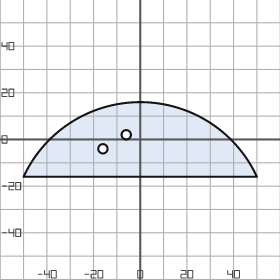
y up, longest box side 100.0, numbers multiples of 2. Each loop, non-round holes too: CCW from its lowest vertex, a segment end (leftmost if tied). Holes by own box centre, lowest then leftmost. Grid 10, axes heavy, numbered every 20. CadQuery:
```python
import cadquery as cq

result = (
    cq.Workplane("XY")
    .moveTo(-50.0, -16.0)
    .lineTo(50.0, -16.0)
    .threePointArc((0.0, 16.0), (-50.0, -16.0))
    .close()
    .moveTo(-16.0, -4.0)
    .circle(2.0)
    .moveTo(-6.0, 2.0)
    .circle(2.0)
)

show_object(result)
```